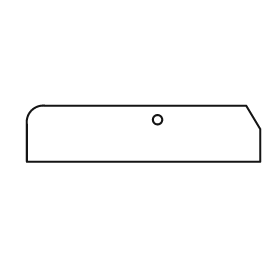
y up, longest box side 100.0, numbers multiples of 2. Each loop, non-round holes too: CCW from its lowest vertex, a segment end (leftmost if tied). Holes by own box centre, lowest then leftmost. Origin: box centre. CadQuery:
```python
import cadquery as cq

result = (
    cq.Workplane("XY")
    .moveTo(-50.0, -12.0)
    .lineTo(50.0, -12.0)
    .lineTo(50.0, 2.0)
    .lineTo(44.0, 12.0)
    .lineTo(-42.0, 12.0)
    .threePointArc((-48.0, 10.0), (-50.0, 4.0))
    .close()
    .moveTo(6.0, 6.0)
    .circle(2.0)
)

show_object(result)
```